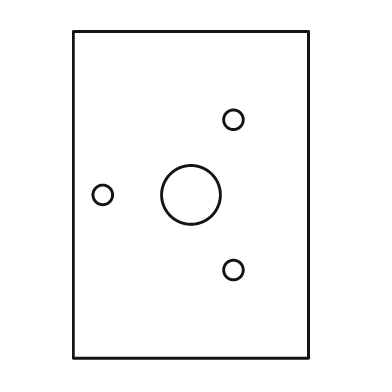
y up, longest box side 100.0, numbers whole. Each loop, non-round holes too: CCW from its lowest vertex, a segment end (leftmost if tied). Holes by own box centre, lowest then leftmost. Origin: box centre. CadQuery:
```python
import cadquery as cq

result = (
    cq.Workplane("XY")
    .moveTo(-36.0, -50.0)
    .lineTo(36.0, -50.0)
    .lineTo(36.0, 50.0)
    .lineTo(-36.0, 50.0)
    .close()
    .moveTo(13.0, -23.0)
    .circle(3.0)
    .moveTo(-27.0, 0.0)
    .circle(3.0)
    .moveTo(0.0, 0.0)
    .circle(9.0)
    .moveTo(13.0, 23.0)
    .circle(3.0)
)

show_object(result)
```